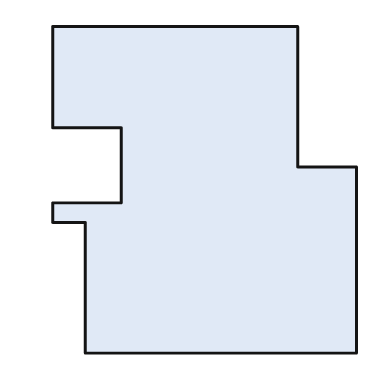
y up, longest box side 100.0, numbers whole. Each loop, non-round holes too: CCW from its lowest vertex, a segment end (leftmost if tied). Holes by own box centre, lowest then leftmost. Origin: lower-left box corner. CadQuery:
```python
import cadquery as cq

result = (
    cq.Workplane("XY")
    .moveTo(10.0, 0.0)
    .lineTo(93.0, 0.0)
    .lineTo(93.0, 57.0)
    .lineTo(75.0, 57.0)
    .lineTo(75.0, 100.0)
    .lineTo(0.0, 100.0)
    .lineTo(0.0, 69.0)
    .lineTo(21.0, 69.0)
    .lineTo(21.0, 46.0)
    .lineTo(0.0, 46.0)
    .lineTo(0.0, 40.0)
    .lineTo(10.0, 40.0)
    .close()
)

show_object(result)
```